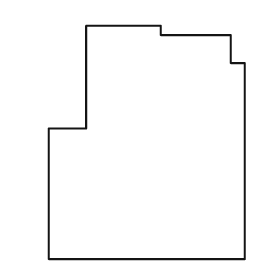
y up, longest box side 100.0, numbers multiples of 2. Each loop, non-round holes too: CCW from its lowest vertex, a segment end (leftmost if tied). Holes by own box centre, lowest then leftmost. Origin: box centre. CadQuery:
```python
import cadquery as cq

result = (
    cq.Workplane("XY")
    .moveTo(-42.0, -50.0)
    .lineTo(42.0, -50.0)
    .lineTo(42.0, 34.0)
    .lineTo(36.0, 34.0)
    .lineTo(36.0, 46.0)
    .lineTo(6.0, 46.0)
    .lineTo(6.0, 50.0)
    .lineTo(-26.0, 50.0)
    .lineTo(-26.0, 6.0)
    .lineTo(-42.0, 6.0)
    .close()
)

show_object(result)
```